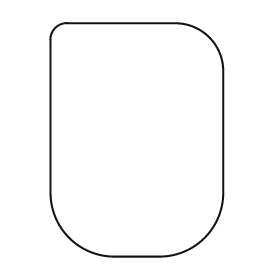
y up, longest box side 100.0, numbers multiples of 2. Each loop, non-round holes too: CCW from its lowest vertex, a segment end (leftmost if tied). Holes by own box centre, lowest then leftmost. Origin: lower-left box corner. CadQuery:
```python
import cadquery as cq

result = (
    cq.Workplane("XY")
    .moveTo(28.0, 0.0)
    .lineTo(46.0, 0.0)
    .threePointArc((66.0, 8.0), (74.0, 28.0))
    .lineTo(74.0, 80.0)
    .threePointArc((68.0, 94.0), (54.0, 100.0))
    .lineTo(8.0, 100.0)
    .threePointArc((2.0, 98.0), (0.0, 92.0))
    .lineTo(0.0, 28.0)
    .threePointArc((8.0, 8.0), (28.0, 0.0))
    .close()
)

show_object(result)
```